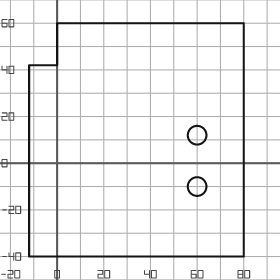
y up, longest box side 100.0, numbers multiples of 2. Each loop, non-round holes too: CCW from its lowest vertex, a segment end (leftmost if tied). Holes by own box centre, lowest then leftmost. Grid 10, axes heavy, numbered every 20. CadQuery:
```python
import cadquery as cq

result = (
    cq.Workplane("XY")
    .moveTo(-12.0, -40.0)
    .lineTo(80.0, -40.0)
    .lineTo(80.0, 60.0)
    .lineTo(0.0, 60.0)
    .lineTo(0.0, 42.0)
    .lineTo(-12.0, 42.0)
    .close()
    .moveTo(60.0, -10.0)
    .circle(4.0)
    .moveTo(60.0, 12.0)
    .circle(4.0)
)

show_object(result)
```